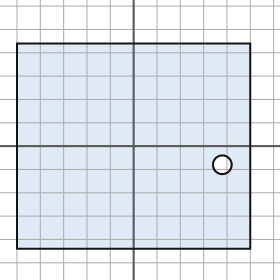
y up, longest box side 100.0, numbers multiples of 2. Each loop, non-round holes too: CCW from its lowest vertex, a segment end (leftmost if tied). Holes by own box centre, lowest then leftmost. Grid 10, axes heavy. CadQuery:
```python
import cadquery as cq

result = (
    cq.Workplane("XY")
    .moveTo(-50.0, -44.0)
    .lineTo(50.0, -44.0)
    .lineTo(50.0, 44.0)
    .lineTo(-50.0, 44.0)
    .close()
    .moveTo(38.0, -8.0)
    .circle(4.0)
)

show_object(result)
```